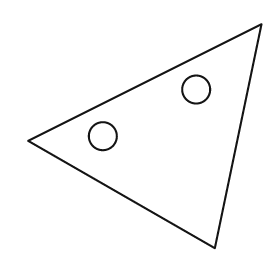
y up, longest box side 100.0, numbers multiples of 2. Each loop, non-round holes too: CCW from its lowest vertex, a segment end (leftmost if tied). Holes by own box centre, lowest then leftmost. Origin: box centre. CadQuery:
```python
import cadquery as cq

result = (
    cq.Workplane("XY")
    .moveTo(30.0, -48.0)
    .lineTo(50.0, 48.0)
    .lineTo(-50.0, -2.0)
    .close()
    .moveTo(-18.0, 0.0)
    .circle(6.0)
    .moveTo(22.0, 20.0)
    .circle(6.0)
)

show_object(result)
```